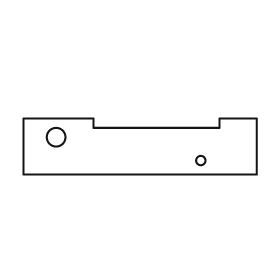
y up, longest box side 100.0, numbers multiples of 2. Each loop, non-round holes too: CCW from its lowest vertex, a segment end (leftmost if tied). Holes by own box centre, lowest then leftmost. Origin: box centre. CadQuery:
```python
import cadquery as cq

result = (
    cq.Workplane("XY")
    .moveTo(-50.0, -12.0)
    .lineTo(50.0, -12.0)
    .lineTo(50.0, 12.0)
    .lineTo(34.0, 12.0)
    .lineTo(34.0, 8.0)
    .lineTo(-20.0, 8.0)
    .lineTo(-20.0, 12.0)
    .lineTo(-50.0, 12.0)
    .close()
    .moveTo(26.0, -6.0)
    .circle(2.0)
    .moveTo(-36.0, 4.0)
    .circle(4.0)
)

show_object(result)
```